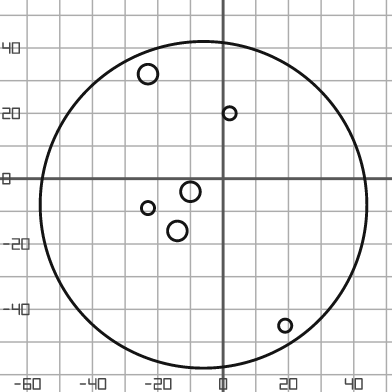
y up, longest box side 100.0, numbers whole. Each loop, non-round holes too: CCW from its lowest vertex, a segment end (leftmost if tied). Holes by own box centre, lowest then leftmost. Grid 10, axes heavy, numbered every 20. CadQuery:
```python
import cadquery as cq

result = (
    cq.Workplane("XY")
    .moveTo(-6.0, -8.0)
    .circle(50.0)
    .moveTo(19.0, -45.0)
    .circle(2.0)
    .moveTo(-14.0, -16.0)
    .circle(3.0)
    .moveTo(-23.0, -9.0)
    .circle(2.0)
    .moveTo(-10.0, -4.0)
    .circle(3.0)
    .moveTo(2.0, 20.0)
    .circle(2.0)
    .moveTo(-23.0, 32.0)
    .circle(3.0)
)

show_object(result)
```